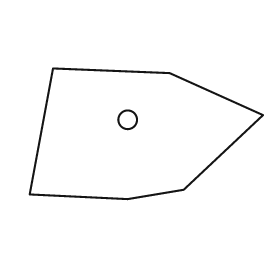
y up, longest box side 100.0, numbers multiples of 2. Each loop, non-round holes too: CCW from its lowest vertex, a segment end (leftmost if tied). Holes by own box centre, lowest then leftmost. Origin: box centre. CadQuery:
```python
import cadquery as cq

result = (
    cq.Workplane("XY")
    .moveTo(-8.0, -28.0)
    .lineTo(16.0, -24.0)
    .lineTo(50.0, 8.0)
    .lineTo(10.0, 26.0)
    .lineTo(-40.0, 28.0)
    .lineTo(-50.0, -26.0)
    .close()
    .moveTo(-8.0, 6.0)
    .circle(4.0)
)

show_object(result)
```